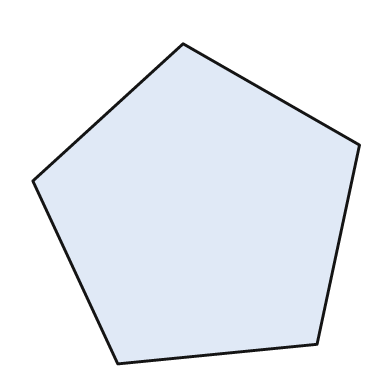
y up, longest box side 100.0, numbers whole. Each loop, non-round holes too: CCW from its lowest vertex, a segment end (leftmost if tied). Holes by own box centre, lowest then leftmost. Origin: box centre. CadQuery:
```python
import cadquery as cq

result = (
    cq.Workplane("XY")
    .moveTo(-24.0, -49.0)
    .lineTo(37.0, -43.0)
    .lineTo(50.0, 18.0)
    .lineTo(-4.0, 49.0)
    .lineTo(-50.0, 7.0)
    .close()
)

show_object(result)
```